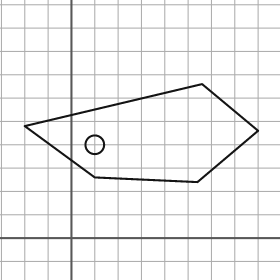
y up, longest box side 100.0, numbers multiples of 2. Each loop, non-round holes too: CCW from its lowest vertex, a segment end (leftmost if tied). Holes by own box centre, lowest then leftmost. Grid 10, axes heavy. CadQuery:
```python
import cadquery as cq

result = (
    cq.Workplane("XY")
    .moveTo(54.0, 24.0)
    .lineTo(80.0, 46.0)
    .lineTo(56.0, 66.0)
    .lineTo(-20.0, 48.0)
    .lineTo(10.0, 26.0)
    .close()
    .moveTo(10.0, 40.0)
    .circle(4.0)
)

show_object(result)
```